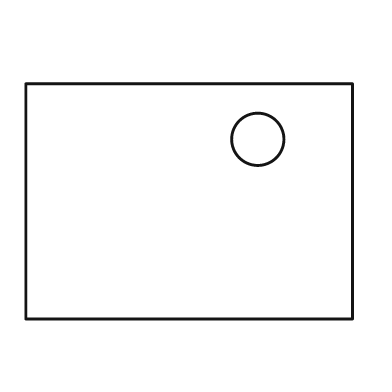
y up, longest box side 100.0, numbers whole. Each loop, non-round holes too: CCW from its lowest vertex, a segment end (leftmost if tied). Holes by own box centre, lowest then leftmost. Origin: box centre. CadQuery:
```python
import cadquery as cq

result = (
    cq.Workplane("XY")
    .moveTo(-50.0, -36.0)
    .lineTo(50.0, -36.0)
    .lineTo(50.0, 36.0)
    .lineTo(-50.0, 36.0)
    .close()
    .moveTo(21.0, 19.0)
    .circle(8.0)
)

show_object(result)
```